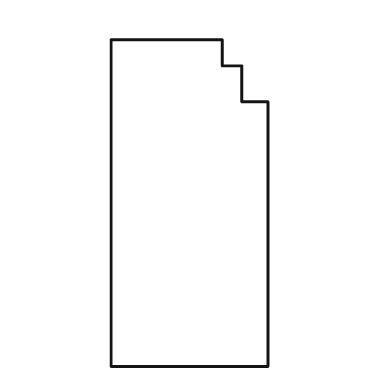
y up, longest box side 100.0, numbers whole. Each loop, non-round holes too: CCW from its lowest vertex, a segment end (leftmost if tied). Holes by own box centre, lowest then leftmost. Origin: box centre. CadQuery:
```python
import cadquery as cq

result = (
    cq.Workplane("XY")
    .moveTo(-24.0, -50.0)
    .lineTo(24.0, -50.0)
    .lineTo(24.0, 31.0)
    .lineTo(16.0, 31.0)
    .lineTo(16.0, 42.0)
    .lineTo(10.0, 42.0)
    .lineTo(10.0, 50.0)
    .lineTo(-24.0, 50.0)
    .close()
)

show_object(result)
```